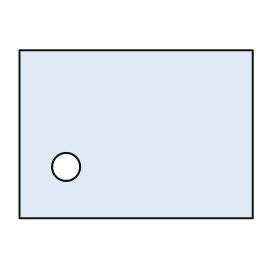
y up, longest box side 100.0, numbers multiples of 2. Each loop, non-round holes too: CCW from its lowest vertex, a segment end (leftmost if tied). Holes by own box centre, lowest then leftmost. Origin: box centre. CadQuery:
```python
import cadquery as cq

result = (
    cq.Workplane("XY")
    .moveTo(-50.0, -36.0)
    .lineTo(50.0, -36.0)
    .lineTo(50.0, 36.0)
    .lineTo(-50.0, 36.0)
    .close()
    .moveTo(-30.0, -14.0)
    .circle(6.0)
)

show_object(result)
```